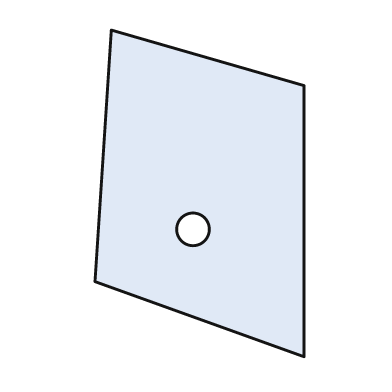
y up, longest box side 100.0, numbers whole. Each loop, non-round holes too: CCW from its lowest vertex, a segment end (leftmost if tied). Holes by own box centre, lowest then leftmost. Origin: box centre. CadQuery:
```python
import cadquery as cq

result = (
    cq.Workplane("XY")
    .moveTo(32.0, -50.0)
    .lineTo(32.0, 33.0)
    .lineTo(-27.0, 50.0)
    .lineTo(-32.0, -27.0)
    .close()
    .moveTo(-2.0, -11.0)
    .circle(5.0)
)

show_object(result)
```